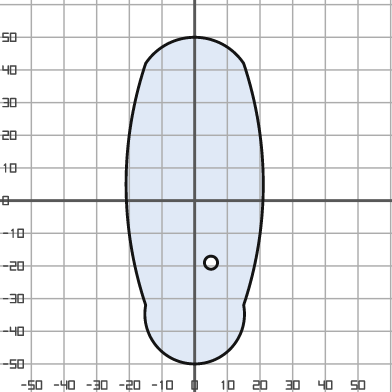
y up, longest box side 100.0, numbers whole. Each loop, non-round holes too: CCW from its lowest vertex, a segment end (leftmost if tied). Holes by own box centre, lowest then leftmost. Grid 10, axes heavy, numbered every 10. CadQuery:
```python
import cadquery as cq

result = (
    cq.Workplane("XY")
    .moveTo(-15.0, -32.0)
    .threePointArc((0.0, -50.0), (15.0, -32.0))
    .threePointArc((21.0, 5.0), (15.0, 42.0))
    .threePointArc((0.0, 50.0), (-15.0, 42.0))
    .threePointArc((-21.0, 5.0), (-15.0, -32.0))
    .close()
    .moveTo(5.0, -19.0)
    .circle(2.0)
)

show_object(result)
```